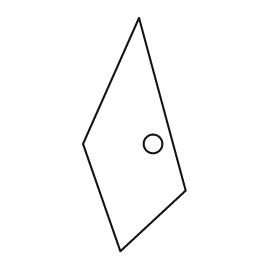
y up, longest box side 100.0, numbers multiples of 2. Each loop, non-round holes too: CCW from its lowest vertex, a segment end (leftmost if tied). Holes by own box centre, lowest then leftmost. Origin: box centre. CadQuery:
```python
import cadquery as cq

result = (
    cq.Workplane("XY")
    .moveTo(-6.0, -50.0)
    .lineTo(22.0, -24.0)
    .lineTo(2.0, 50.0)
    .lineTo(-22.0, -4.0)
    .close()
    .moveTo(8.0, -4.0)
    .circle(4.0)
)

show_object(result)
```